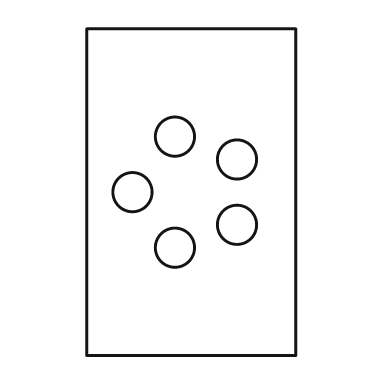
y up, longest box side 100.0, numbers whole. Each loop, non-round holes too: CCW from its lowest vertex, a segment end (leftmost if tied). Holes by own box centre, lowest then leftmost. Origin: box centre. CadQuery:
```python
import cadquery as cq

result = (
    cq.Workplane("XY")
    .moveTo(-32.0, -50.0)
    .lineTo(32.0, -50.0)
    .lineTo(32.0, 50.0)
    .lineTo(-32.0, 50.0)
    .close()
    .moveTo(-5.0, -17.0)
    .circle(6.0)
    .moveTo(14.0, -10.0)
    .circle(6.0)
    .moveTo(-18.0, 0.0)
    .circle(6.0)
    .moveTo(14.0, 10.0)
    .circle(6.0)
    .moveTo(-5.0, 17.0)
    .circle(6.0)
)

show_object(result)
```